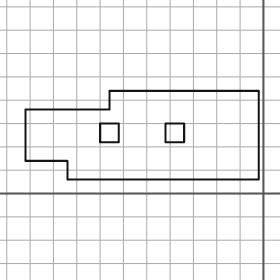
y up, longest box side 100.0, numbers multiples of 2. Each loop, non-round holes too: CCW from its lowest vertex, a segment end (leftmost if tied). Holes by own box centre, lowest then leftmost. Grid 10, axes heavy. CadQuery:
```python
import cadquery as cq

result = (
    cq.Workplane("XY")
    .moveTo(-84.0, 6.0)
    .lineTo(-2.0, 6.0)
    .lineTo(-2.0, 44.0)
    .lineTo(-66.0, 44.0)
    .lineTo(-66.0, 36.0)
    .lineTo(-102.0, 36.0)
    .lineTo(-102.0, 14.0)
    .lineTo(-84.0, 14.0)
    .close()
    .moveTo(-70.0, 22.0)
    .lineTo(-62.0, 22.0)
    .lineTo(-62.0, 30.0)
    .lineTo(-70.0, 30.0)
    .close()
    .moveTo(-42.0, 22.0)
    .lineTo(-34.0, 22.0)
    .lineTo(-34.0, 30.0)
    .lineTo(-42.0, 30.0)
    .close()
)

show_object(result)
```